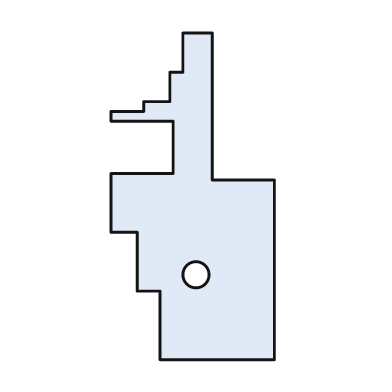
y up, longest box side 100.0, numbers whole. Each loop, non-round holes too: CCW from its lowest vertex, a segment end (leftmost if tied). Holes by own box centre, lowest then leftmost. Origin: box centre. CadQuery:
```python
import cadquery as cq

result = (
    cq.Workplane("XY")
    .moveTo(-10.0, -50.0)
    .lineTo(25.0, -50.0)
    .lineTo(25.0, 5.0)
    .lineTo(6.0, 5.0)
    .lineTo(6.0, 50.0)
    .lineTo(-3.0, 50.0)
    .lineTo(-3.0, 38.0)
    .lineTo(-7.0, 38.0)
    .lineTo(-7.0, 29.0)
    .lineTo(-15.0, 29.0)
    .lineTo(-15.0, 26.0)
    .lineTo(-25.0, 26.0)
    .lineTo(-25.0, 23.0)
    .lineTo(-6.0, 23.0)
    .lineTo(-6.0, 7.0)
    .lineTo(-25.0, 7.0)
    .lineTo(-25.0, -11.0)
    .lineTo(-17.0, -11.0)
    .lineTo(-17.0, -29.0)
    .lineTo(-10.0, -29.0)
    .close()
    .moveTo(1.0, -24.0)
    .circle(4.0)
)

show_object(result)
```